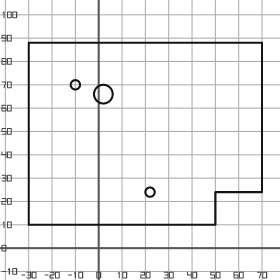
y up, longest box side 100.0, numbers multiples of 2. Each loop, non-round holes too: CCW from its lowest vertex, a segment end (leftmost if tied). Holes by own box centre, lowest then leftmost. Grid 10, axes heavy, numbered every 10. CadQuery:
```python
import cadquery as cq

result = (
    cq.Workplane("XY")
    .moveTo(-30.0, 10.0)
    .lineTo(50.0, 10.0)
    .lineTo(50.0, 24.0)
    .lineTo(70.0, 24.0)
    .lineTo(70.0, 88.0)
    .lineTo(-30.0, 88.0)
    .close()
    .moveTo(22.0, 24.0)
    .circle(2.0)
    .moveTo(2.0, 66.0)
    .circle(4.0)
    .moveTo(-10.0, 70.0)
    .circle(2.0)
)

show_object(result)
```